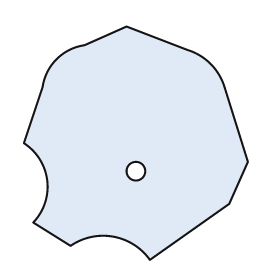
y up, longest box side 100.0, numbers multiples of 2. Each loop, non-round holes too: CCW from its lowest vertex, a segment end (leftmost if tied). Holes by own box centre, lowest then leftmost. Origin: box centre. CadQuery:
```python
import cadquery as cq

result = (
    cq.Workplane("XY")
    .moveTo(6.0, -50.0)
    .lineTo(40.0, -26.0)
    .lineTo(48.0, -8.0)
    .lineTo(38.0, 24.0)
    .threePointArc((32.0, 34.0), (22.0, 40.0))
    .lineTo(-4.0, 50.0)
    .lineTo(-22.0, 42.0)
    .threePointArc((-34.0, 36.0), (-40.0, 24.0))
    .lineTo(-48.0, 0.0)
    .threePointArc((-38.0, -16.0), (-44.0, -34.0))
    .lineTo(-28.0, -44.0)
    .threePointArc((-10.0, -40.0), (6.0, -50.0))
    .close()
    .moveTo(0.0, -12.0)
    .circle(4.0)
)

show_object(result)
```